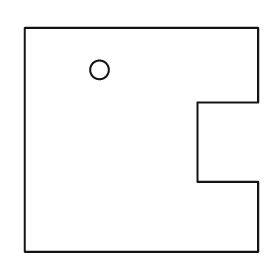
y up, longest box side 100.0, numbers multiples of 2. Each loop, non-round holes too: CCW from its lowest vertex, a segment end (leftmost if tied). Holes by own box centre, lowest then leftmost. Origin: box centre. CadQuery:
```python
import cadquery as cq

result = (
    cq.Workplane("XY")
    .moveTo(-50.0, -48.0)
    .lineTo(50.0, -48.0)
    .lineTo(50.0, -18.0)
    .lineTo(24.0, -18.0)
    .lineTo(24.0, 16.0)
    .lineTo(50.0, 16.0)
    .lineTo(50.0, 48.0)
    .lineTo(-50.0, 48.0)
    .close()
    .moveTo(-18.0, 30.0)
    .circle(4.0)
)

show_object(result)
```